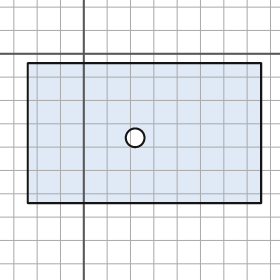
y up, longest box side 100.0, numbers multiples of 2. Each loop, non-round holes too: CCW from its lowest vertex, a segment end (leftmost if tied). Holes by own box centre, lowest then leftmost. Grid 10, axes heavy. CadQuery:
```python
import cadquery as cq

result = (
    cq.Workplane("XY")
    .moveTo(-24.0, -64.0)
    .lineTo(76.0, -64.0)
    .lineTo(76.0, -4.0)
    .lineTo(-24.0, -4.0)
    .close()
    .moveTo(22.0, -36.0)
    .circle(4.0)
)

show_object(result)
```